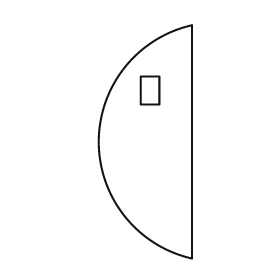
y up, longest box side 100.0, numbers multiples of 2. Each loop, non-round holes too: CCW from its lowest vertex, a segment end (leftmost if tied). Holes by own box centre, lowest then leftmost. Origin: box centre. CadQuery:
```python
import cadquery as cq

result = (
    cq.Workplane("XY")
    .moveTo(20.0, -50.0)
    .lineTo(20.0, 50.0)
    .threePointArc((-20.0, 0.0), (20.0, -50.0))
    .close()
    .moveTo(-2.0, 16.0)
    .lineTo(6.0, 16.0)
    .lineTo(6.0, 28.0)
    .lineTo(-2.0, 28.0)
    .close()
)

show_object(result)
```